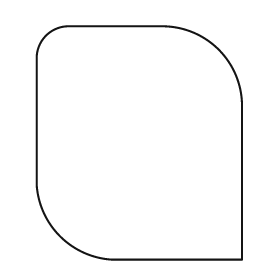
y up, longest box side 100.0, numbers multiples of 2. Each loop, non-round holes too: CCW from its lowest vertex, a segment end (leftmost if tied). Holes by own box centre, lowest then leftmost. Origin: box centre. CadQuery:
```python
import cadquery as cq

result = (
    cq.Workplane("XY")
    .moveTo(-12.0, -50.0)
    .lineTo(44.0, -50.0)
    .lineTo(44.0, 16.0)
    .threePointArc((34.0, 40.0), (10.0, 50.0))
    .lineTo(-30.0, 50.0)
    .threePointArc((-40.0, 46.0), (-44.0, 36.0))
    .lineTo(-44.0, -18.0)
    .threePointArc((-34.0, -40.0), (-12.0, -50.0))
    .close()
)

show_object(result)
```